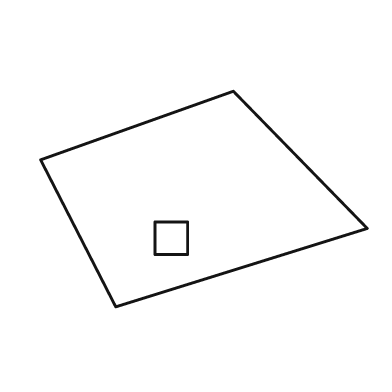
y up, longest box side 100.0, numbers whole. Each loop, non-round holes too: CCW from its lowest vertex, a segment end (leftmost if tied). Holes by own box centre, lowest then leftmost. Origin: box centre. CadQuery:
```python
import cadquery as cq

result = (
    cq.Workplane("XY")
    .moveTo(-27.0, -33.0)
    .lineTo(50.0, -9.0)
    .lineTo(9.0, 33.0)
    .lineTo(-50.0, 12.0)
    .close()
    .moveTo(-15.0, -17.0)
    .lineTo(-5.0, -17.0)
    .lineTo(-5.0, -7.0)
    .lineTo(-15.0, -7.0)
    .close()
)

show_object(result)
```